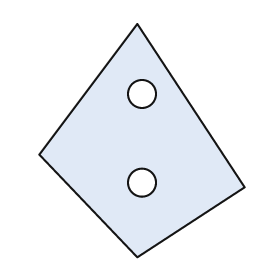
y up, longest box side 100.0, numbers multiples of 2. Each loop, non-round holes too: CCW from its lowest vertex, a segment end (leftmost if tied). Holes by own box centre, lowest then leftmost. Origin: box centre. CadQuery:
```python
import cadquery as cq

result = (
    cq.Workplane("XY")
    .moveTo(-2.0, -50.0)
    .lineTo(44.0, -20.0)
    .lineTo(-2.0, 50.0)
    .lineTo(-44.0, -6.0)
    .close()
    .moveTo(0.0, -18.0)
    .circle(6.0)
    .moveTo(0.0, 20.0)
    .circle(6.0)
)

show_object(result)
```